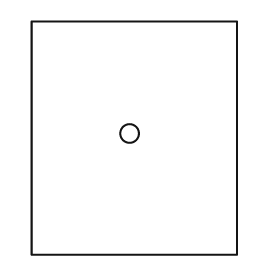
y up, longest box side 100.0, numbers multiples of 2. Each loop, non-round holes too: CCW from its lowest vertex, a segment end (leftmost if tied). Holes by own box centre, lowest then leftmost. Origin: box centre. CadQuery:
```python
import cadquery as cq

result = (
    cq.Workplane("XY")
    .moveTo(-44.0, -50.0)
    .lineTo(44.0, -50.0)
    .lineTo(44.0, 50.0)
    .lineTo(-44.0, 50.0)
    .close()
    .moveTo(-2.0, 2.0)
    .circle(4.0)
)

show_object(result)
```